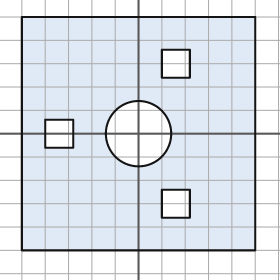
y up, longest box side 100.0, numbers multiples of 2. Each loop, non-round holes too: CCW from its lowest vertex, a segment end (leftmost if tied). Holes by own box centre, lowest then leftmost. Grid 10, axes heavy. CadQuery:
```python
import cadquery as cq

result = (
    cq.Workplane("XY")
    .moveTo(-50.0, -50.0)
    .lineTo(50.0, -50.0)
    .lineTo(50.0, 50.0)
    .lineTo(-50.0, 50.0)
    .close()
    .moveTo(10.0, -36.0)
    .lineTo(22.0, -36.0)
    .lineTo(22.0, -24.0)
    .lineTo(10.0, -24.0)
    .close()
    .moveTo(-40.0, -6.0)
    .lineTo(-28.0, -6.0)
    .lineTo(-28.0, 6.0)
    .lineTo(-40.0, 6.0)
    .close()
    .moveTo(0.0, 0.0)
    .circle(14.0)
    .moveTo(10.0, 24.0)
    .lineTo(22.0, 24.0)
    .lineTo(22.0, 36.0)
    .lineTo(10.0, 36.0)
    .close()
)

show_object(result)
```